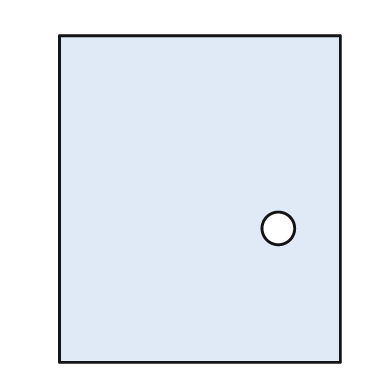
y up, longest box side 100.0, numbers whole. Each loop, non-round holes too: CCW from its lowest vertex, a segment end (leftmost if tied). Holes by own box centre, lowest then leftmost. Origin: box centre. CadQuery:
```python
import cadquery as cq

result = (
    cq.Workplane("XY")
    .moveTo(-43.0, -50.0)
    .lineTo(43.0, -50.0)
    .lineTo(43.0, 50.0)
    .lineTo(-43.0, 50.0)
    .close()
    .moveTo(24.0, -9.0)
    .circle(5.0)
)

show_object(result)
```